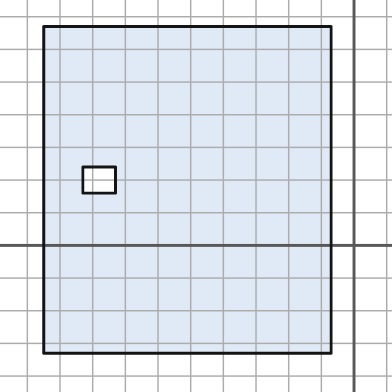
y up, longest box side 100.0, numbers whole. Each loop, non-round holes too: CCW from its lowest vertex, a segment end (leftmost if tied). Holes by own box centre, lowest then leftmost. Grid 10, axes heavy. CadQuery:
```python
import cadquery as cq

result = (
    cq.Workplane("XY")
    .moveTo(-95.0, -33.0)
    .lineTo(-7.0, -33.0)
    .lineTo(-7.0, 67.0)
    .lineTo(-95.0, 67.0)
    .close()
    .moveTo(-83.0, 16.0)
    .lineTo(-73.0, 16.0)
    .lineTo(-73.0, 24.0)
    .lineTo(-83.0, 24.0)
    .close()
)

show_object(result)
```